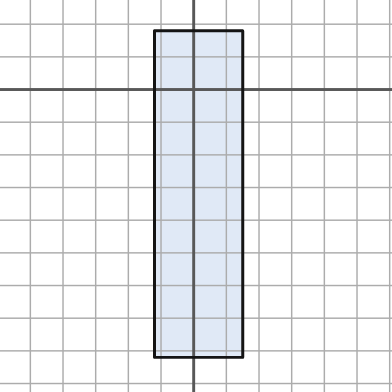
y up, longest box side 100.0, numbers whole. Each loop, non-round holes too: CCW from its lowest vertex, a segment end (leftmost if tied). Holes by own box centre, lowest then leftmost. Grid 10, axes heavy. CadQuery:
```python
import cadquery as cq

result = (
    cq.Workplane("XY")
    .moveTo(-12.0, -82.0)
    .lineTo(15.0, -82.0)
    .lineTo(15.0, 18.0)
    .lineTo(-12.0, 18.0)
    .close()
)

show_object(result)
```